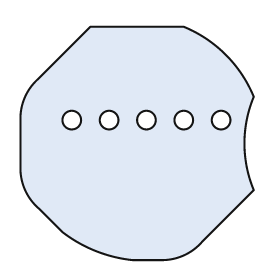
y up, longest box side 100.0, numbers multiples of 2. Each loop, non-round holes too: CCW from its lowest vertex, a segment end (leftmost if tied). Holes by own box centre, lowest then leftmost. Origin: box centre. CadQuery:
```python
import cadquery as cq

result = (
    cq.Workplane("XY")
    .moveTo(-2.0, -50.0)
    .lineTo(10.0, -50.0)
    .threePointArc((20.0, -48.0), (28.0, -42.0))
    .lineTo(50.0, -20.0)
    .threePointArc((46.0, 0.0), (50.0, 20.0))
    .threePointArc((38.0, 38.0), (20.0, 50.0))
    .lineTo(-20.0, 50.0)
    .lineTo(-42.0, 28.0)
    .threePointArc((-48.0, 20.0), (-50.0, 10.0))
    .lineTo(-50.0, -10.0)
    .threePointArc((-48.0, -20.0), (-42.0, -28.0))
    .lineTo(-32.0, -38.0)
    .threePointArc((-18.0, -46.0), (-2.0, -50.0))
    .close()
    .moveTo(-28.0, 10.0)
    .circle(4.0)
    .moveTo(-12.0, 10.0)
    .circle(4.0)
    .moveTo(4.0, 10.0)
    .circle(4.0)
    .moveTo(20.0, 10.0)
    .circle(4.0)
    .moveTo(36.0, 10.0)
    .circle(4.0)
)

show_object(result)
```